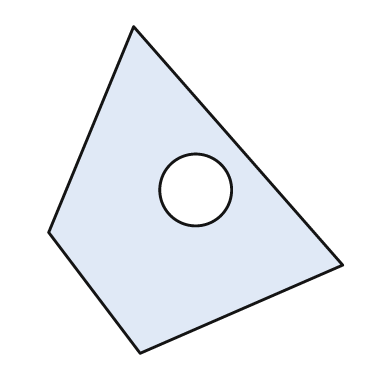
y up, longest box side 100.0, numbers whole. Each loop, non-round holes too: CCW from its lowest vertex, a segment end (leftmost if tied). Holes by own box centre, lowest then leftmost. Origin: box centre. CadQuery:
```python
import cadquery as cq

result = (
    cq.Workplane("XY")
    .moveTo(-17.0, -50.0)
    .lineTo(45.0, -23.0)
    .lineTo(-19.0, 50.0)
    .lineTo(-45.0, -13.0)
    .close()
    .moveTo(0.0, 0.0)
    .circle(11.0)
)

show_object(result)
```